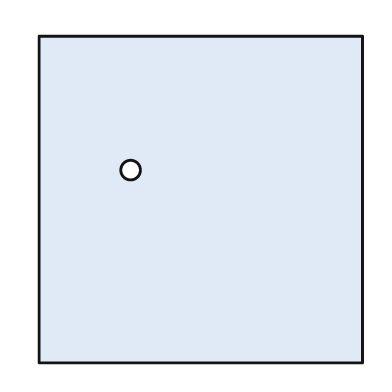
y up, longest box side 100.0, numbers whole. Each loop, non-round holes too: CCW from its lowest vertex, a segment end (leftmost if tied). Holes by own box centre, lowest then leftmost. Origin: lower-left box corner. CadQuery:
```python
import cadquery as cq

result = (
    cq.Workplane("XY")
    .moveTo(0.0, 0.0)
    .lineTo(99.0, 0.0)
    .lineTo(99.0, 100.0)
    .lineTo(0.0, 100.0)
    .close()
    .moveTo(28.0, 59.0)
    .circle(3.0)
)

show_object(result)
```